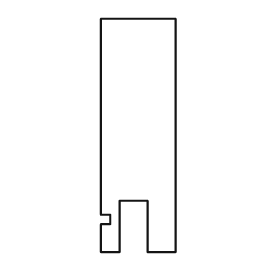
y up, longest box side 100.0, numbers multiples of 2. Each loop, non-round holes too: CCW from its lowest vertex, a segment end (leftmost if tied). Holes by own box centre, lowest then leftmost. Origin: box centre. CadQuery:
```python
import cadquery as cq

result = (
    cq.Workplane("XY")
    .moveTo(-16.0, -50.0)
    .lineTo(-8.0, -50.0)
    .lineTo(-8.0, -28.0)
    .lineTo(4.0, -28.0)
    .lineTo(4.0, -50.0)
    .lineTo(16.0, -50.0)
    .lineTo(16.0, 50.0)
    .lineTo(-16.0, 50.0)
    .lineTo(-16.0, -34.0)
    .lineTo(-12.0, -34.0)
    .lineTo(-12.0, -38.0)
    .lineTo(-16.0, -38.0)
    .close()
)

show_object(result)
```